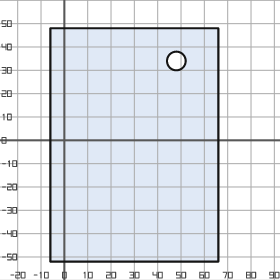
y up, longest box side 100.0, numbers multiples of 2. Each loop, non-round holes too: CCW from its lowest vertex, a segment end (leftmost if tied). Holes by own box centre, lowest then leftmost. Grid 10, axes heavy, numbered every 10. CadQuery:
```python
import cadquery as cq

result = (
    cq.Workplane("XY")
    .moveTo(-6.0, -52.0)
    .lineTo(66.0, -52.0)
    .lineTo(66.0, 48.0)
    .lineTo(-6.0, 48.0)
    .close()
    .moveTo(48.0, 34.0)
    .circle(4.0)
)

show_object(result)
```